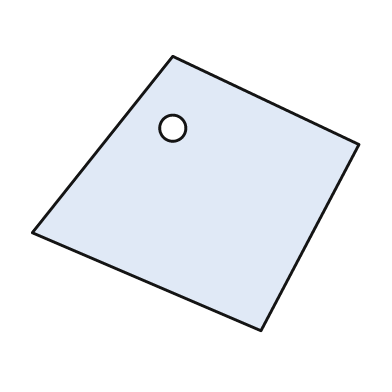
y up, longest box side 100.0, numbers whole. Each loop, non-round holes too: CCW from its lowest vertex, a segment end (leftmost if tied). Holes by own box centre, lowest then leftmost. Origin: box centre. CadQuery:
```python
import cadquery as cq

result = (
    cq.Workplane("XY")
    .moveTo(20.0, -42.0)
    .lineTo(50.0, 15.0)
    .lineTo(-7.0, 42.0)
    .lineTo(-50.0, -12.0)
    .close()
    .moveTo(-7.0, 20.0)
    .circle(4.0)
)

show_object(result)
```